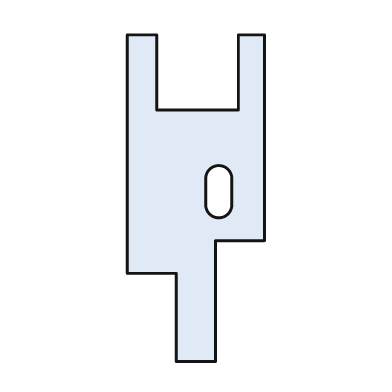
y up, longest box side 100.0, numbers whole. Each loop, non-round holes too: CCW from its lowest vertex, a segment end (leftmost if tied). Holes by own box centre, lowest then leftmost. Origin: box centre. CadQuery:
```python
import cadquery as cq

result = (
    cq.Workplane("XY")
    .moveTo(-6.0, -50.0)
    .lineTo(6.0, -50.0)
    .lineTo(6.0, -13.0)
    .lineTo(21.0, -13.0)
    .lineTo(21.0, 50.0)
    .lineTo(13.0, 50.0)
    .lineTo(13.0, 27.0)
    .lineTo(-12.0, 27.0)
    .lineTo(-12.0, 50.0)
    .lineTo(-21.0, 50.0)
    .lineTo(-21.0, -23.0)
    .lineTo(-6.0, -23.0)
    .close()
    .moveTo(3.0, -2.0)
    .threePointArc((7.0, -6.0), (11.0, -2.0))
    .lineTo(11.0, 6.0)
    .threePointArc((7.0, 10.0), (3.0, 6.0))
    .close()
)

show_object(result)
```